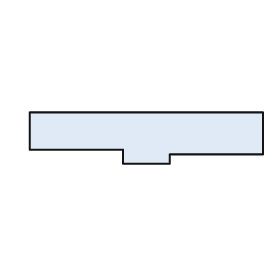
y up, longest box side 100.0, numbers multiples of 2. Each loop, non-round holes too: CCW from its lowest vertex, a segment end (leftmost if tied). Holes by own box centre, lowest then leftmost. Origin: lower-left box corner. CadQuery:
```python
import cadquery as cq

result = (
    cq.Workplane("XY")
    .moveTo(40.0, 0.0)
    .lineTo(60.0, 0.0)
    .lineTo(60.0, 4.0)
    .lineTo(100.0, 4.0)
    .lineTo(100.0, 22.0)
    .lineTo(0.0, 22.0)
    .lineTo(0.0, 6.0)
    .lineTo(40.0, 6.0)
    .close()
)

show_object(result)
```